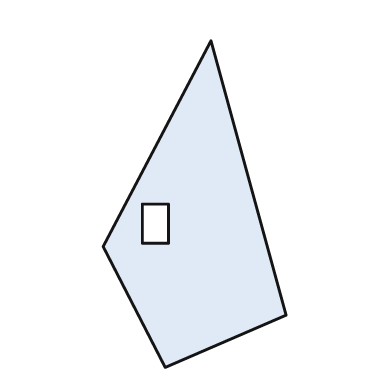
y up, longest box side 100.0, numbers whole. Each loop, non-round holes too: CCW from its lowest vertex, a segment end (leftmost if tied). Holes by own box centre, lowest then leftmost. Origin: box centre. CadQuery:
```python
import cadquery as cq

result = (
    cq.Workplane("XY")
    .moveTo(-9.0, -50.0)
    .lineTo(28.0, -34.0)
    .lineTo(5.0, 50.0)
    .lineTo(-28.0, -13.0)
    .close()
    .moveTo(-16.0, -12.0)
    .lineTo(-8.0, -12.0)
    .lineTo(-8.0, 0.0)
    .lineTo(-16.0, 0.0)
    .close()
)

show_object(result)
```